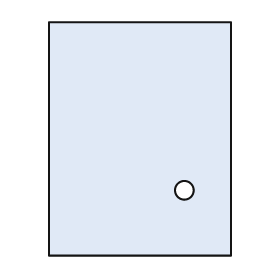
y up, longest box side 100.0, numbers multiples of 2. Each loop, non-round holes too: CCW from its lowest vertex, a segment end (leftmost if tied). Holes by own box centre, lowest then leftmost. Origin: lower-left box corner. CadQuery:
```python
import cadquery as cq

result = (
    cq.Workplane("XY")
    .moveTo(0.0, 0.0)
    .lineTo(78.0, 0.0)
    .lineTo(78.0, 100.0)
    .lineTo(0.0, 100.0)
    .close()
    .moveTo(58.0, 28.0)
    .circle(4.0)
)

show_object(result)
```